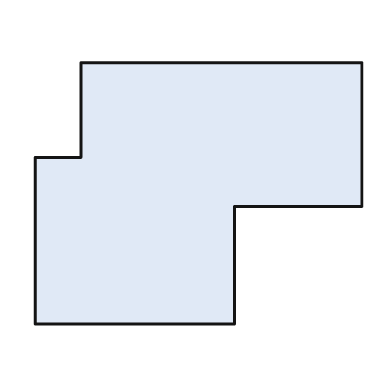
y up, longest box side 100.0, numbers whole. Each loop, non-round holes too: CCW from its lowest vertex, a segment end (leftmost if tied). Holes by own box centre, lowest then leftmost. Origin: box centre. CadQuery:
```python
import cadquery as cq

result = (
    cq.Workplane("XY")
    .moveTo(-50.0, -40.0)
    .lineTo(11.0, -40.0)
    .lineTo(11.0, -4.0)
    .lineTo(50.0, -4.0)
    .lineTo(50.0, 40.0)
    .lineTo(-36.0, 40.0)
    .lineTo(-36.0, 11.0)
    .lineTo(-50.0, 11.0)
    .close()
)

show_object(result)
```